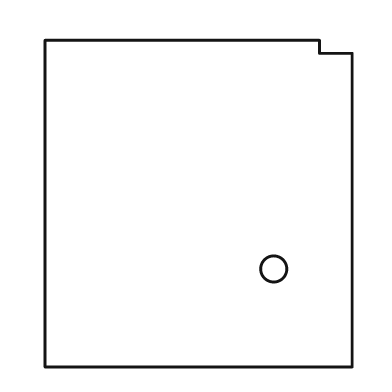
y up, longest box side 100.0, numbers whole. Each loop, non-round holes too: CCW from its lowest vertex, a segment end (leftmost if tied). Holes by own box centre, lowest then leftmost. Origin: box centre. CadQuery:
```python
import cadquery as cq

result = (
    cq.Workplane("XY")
    .moveTo(-47.0, -50.0)
    .lineTo(47.0, -50.0)
    .lineTo(47.0, 46.0)
    .lineTo(37.0, 46.0)
    .lineTo(37.0, 50.0)
    .lineTo(-47.0, 50.0)
    .close()
    .moveTo(23.0, -20.0)
    .circle(4.0)
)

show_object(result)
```